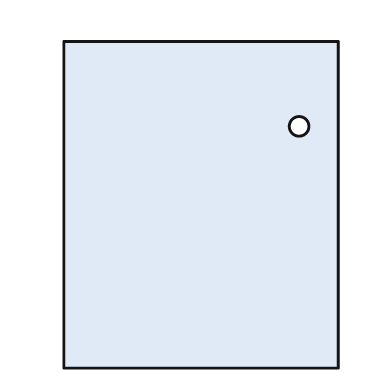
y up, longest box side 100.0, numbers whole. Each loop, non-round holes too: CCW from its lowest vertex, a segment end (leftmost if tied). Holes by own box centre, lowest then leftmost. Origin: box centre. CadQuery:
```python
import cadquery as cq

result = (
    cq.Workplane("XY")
    .moveTo(-42.0, -50.0)
    .lineTo(42.0, -50.0)
    .lineTo(42.0, 50.0)
    .lineTo(-42.0, 50.0)
    .close()
    .moveTo(30.0, 24.0)
    .circle(3.0)
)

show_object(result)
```